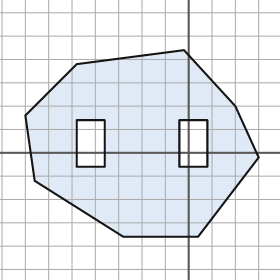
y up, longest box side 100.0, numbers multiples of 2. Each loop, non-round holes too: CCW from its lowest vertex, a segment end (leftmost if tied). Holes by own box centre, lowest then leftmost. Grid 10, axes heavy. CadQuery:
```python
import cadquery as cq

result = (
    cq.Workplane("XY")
    .moveTo(-28.0, -36.0)
    .lineTo(4.0, -36.0)
    .lineTo(30.0, -2.0)
    .lineTo(20.0, 20.0)
    .lineTo(-2.0, 44.0)
    .lineTo(-48.0, 38.0)
    .lineTo(-70.0, 16.0)
    .lineTo(-66.0, -12.0)
    .close()
    .moveTo(-48.0, -6.0)
    .lineTo(-36.0, -6.0)
    .lineTo(-36.0, 14.0)
    .lineTo(-48.0, 14.0)
    .close()
    .moveTo(-4.0, -6.0)
    .lineTo(8.0, -6.0)
    .lineTo(8.0, 14.0)
    .lineTo(-4.0, 14.0)
    .close()
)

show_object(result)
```